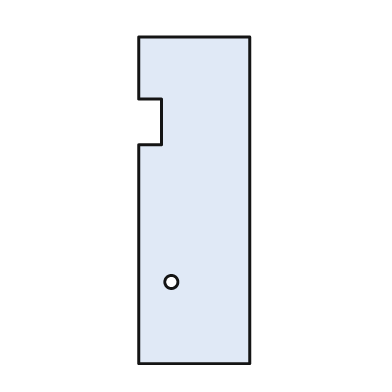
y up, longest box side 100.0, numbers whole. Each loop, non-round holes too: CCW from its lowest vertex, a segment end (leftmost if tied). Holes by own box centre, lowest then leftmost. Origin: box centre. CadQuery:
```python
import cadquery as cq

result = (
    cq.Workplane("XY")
    .moveTo(-17.0, -50.0)
    .lineTo(17.0, -50.0)
    .lineTo(17.0, 50.0)
    .lineTo(-17.0, 50.0)
    .lineTo(-17.0, 31.0)
    .lineTo(-10.0, 31.0)
    .lineTo(-10.0, 17.0)
    .lineTo(-17.0, 17.0)
    .close()
    .moveTo(-7.0, -25.0)
    .circle(2.0)
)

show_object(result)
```